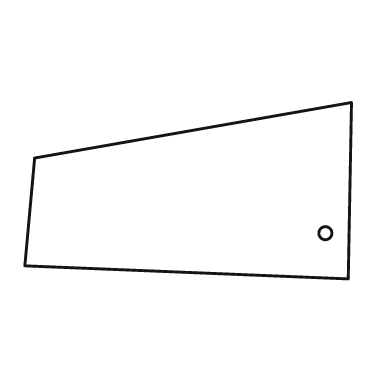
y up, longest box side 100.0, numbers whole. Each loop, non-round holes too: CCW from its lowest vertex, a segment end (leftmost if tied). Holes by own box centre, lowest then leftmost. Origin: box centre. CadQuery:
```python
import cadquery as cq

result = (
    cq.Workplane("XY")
    .moveTo(49.0, -27.0)
    .lineTo(50.0, 27.0)
    .lineTo(-47.0, 10.0)
    .lineTo(-50.0, -23.0)
    .close()
    .moveTo(42.0, -13.0)
    .circle(2.0)
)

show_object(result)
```